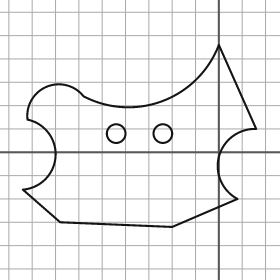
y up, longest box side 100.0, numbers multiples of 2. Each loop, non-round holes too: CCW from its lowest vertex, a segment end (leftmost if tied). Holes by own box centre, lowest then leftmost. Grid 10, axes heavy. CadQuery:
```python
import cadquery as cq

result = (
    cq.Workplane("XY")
    .moveTo(-20.0, -32.0)
    .lineTo(8.0, -20.0)
    .threePointArc((0.0, -2.0), (16.0, 10.0))
    .lineTo(0.0, 46.0)
    .threePointArc((-24.0, 22.0), (-58.0, 24.0))
    .threePointArc((-74.0, 28.0), (-82.0, 14.0))
    .threePointArc((-70.0, -2.0), (-84.0, -16.0))
    .lineTo(-68.0, -30.0)
    .close()
    .moveTo(-44.0, 8.0)
    .circle(4.0)
    .moveTo(-24.0, 8.0)
    .circle(4.0)
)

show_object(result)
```